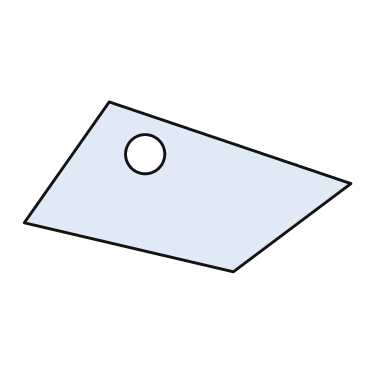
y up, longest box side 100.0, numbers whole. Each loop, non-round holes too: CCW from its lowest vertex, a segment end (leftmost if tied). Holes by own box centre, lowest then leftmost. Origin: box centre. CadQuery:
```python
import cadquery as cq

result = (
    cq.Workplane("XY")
    .moveTo(14.0, -26.0)
    .lineTo(50.0, 1.0)
    .lineTo(-24.0, 26.0)
    .lineTo(-50.0, -11.0)
    .close()
    .moveTo(-13.0, 10.0)
    .circle(6.0)
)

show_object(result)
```